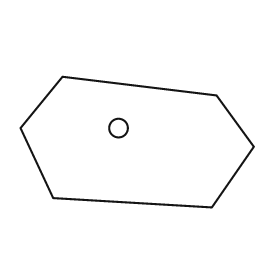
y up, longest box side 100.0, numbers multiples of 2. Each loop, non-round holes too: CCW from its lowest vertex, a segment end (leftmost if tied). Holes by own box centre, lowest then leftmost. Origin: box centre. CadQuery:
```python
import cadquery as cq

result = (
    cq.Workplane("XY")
    .moveTo(32.0, -28.0)
    .lineTo(50.0, -2.0)
    .lineTo(34.0, 20.0)
    .lineTo(-32.0, 28.0)
    .lineTo(-50.0, 6.0)
    .lineTo(-36.0, -24.0)
    .close()
    .moveTo(-8.0, 6.0)
    .circle(4.0)
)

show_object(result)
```